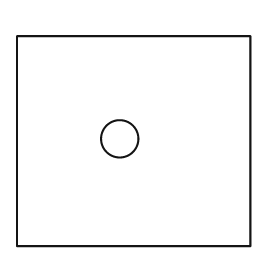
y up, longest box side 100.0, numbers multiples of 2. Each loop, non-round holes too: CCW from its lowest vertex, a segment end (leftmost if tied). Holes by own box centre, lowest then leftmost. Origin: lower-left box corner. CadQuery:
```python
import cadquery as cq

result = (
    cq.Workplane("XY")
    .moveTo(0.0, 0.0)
    .lineTo(100.0, 0.0)
    .lineTo(100.0, 90.0)
    .lineTo(0.0, 90.0)
    .close()
    .moveTo(44.0, 46.0)
    .circle(8.0)
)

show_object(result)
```